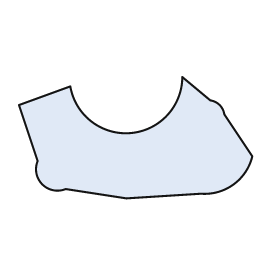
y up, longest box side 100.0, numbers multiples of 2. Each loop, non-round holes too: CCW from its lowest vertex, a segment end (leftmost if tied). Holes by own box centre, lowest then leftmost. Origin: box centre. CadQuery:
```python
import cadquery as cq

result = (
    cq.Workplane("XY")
    .moveTo(-4.0, -26.0)
    .lineTo(28.0, -24.0)
    .threePointArc((42.0, -20.0), (50.0, -8.0))
    .lineTo(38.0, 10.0)
    .threePointArc((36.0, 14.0), (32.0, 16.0))
    .lineTo(20.0, 26.0)
    .threePointArc((-2.0, 2.0), (-28.0, 22.0))
    .lineTo(-50.0, 14.0)
    .lineTo(-42.0, -10.0)
    .threePointArc((-40.0, -20.0), (-30.0, -22.0))
    .close()
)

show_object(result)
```